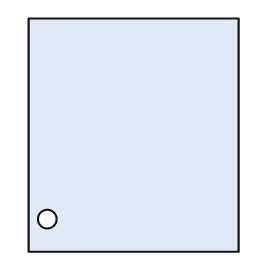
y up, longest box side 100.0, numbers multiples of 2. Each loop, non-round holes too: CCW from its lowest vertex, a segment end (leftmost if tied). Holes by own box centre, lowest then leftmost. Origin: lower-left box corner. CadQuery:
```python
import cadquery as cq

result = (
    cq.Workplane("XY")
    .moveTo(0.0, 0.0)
    .lineTo(90.0, 0.0)
    .lineTo(90.0, 100.0)
    .lineTo(0.0, 100.0)
    .close()
    .moveTo(8.0, 14.0)
    .circle(4.0)
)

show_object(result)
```